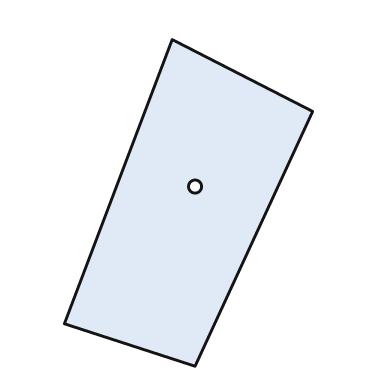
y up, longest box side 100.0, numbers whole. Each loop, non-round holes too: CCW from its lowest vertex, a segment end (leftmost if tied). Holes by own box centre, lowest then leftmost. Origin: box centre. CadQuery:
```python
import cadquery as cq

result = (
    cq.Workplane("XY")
    .moveTo(2.0, -50.0)
    .lineTo(38.0, 28.0)
    .lineTo(-5.0, 50.0)
    .lineTo(-38.0, -37.0)
    .close()
    .moveTo(2.0, 5.0)
    .circle(2.0)
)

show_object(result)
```